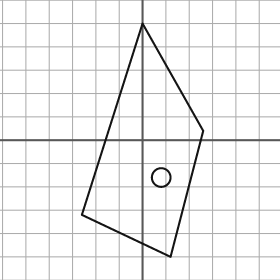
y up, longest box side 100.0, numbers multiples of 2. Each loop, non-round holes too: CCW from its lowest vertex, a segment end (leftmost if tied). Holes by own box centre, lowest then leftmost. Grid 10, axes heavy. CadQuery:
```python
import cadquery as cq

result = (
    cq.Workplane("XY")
    .moveTo(12.0, -50.0)
    .lineTo(26.0, 4.0)
    .lineTo(0.0, 50.0)
    .lineTo(-26.0, -32.0)
    .close()
    .moveTo(8.0, -16.0)
    .circle(4.0)
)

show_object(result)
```